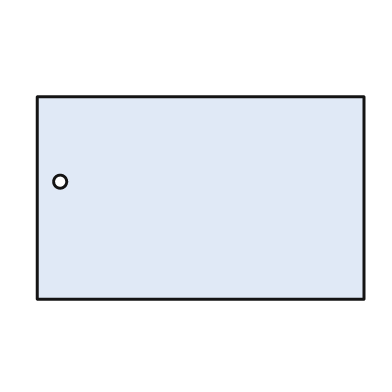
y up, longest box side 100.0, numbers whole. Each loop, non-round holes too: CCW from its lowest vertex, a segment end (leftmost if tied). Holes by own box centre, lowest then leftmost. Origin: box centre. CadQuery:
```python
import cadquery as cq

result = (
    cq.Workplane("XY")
    .moveTo(-50.0, -31.0)
    .lineTo(50.0, -31.0)
    .lineTo(50.0, 31.0)
    .lineTo(-50.0, 31.0)
    .close()
    .moveTo(-43.0, 5.0)
    .circle(2.0)
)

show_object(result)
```